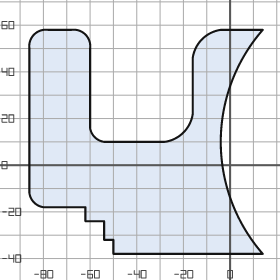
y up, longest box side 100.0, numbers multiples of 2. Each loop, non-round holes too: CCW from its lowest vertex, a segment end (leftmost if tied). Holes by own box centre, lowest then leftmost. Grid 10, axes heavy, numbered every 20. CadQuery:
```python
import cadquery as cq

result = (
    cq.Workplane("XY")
    .moveTo(-50.0, -38.0)
    .lineTo(14.0, -38.0)
    .threePointArc((-4.0, 10.0), (14.0, 58.0))
    .lineTo(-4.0, 58.0)
    .threePointArc((-12.0, 54.0), (-16.0, 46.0))
    .lineTo(-16.0, 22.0)
    .threePointArc((-20.0, 14.0), (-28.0, 10.0))
    .lineTo(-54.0, 10.0)
    .threePointArc((-58.0, 12.0), (-60.0, 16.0))
    .lineTo(-60.0, 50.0)
    .threePointArc((-62.0, 56.0), (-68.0, 58.0))
    .lineTo(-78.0, 58.0)
    .threePointArc((-84.0, 56.0), (-86.0, 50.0))
    .lineTo(-86.0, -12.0)
    .threePointArc((-84.0, -16.0), (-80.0, -18.0))
    .lineTo(-62.0, -18.0)
    .lineTo(-62.0, -24.0)
    .lineTo(-54.0, -24.0)
    .lineTo(-54.0, -32.0)
    .lineTo(-50.0, -32.0)
    .close()
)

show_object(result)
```